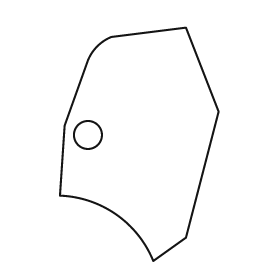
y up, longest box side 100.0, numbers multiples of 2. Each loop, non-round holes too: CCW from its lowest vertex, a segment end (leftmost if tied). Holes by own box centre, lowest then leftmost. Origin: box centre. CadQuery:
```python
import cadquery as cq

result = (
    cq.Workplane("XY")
    .moveTo(6.0, -50.0)
    .lineTo(20.0, -40.0)
    .lineTo(34.0, 14.0)
    .lineTo(20.0, 50.0)
    .lineTo(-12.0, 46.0)
    .threePointArc((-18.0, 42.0), (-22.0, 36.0))
    .lineTo(-32.0, 8.0)
    .lineTo(-34.0, -22.0)
    .threePointArc((-10.0, -30.0), (6.0, -50.0))
    .close()
    .moveTo(-22.0, 4.0)
    .circle(6.0)
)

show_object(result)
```